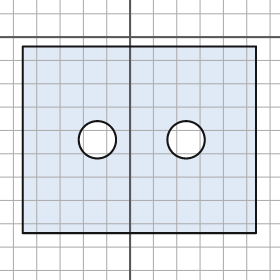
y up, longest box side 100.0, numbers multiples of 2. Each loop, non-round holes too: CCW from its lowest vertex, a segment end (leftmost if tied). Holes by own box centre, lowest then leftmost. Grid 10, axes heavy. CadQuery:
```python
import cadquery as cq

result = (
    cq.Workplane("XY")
    .moveTo(-46.0, -84.0)
    .lineTo(54.0, -84.0)
    .lineTo(54.0, -4.0)
    .lineTo(-46.0, -4.0)
    .close()
    .moveTo(-14.0, -44.0)
    .circle(8.0)
    .moveTo(24.0, -44.0)
    .circle(8.0)
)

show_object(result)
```